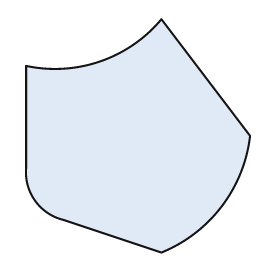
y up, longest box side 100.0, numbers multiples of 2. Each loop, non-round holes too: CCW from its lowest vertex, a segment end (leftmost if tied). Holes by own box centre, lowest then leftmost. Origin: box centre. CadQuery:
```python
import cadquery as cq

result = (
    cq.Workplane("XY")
    .moveTo(10.0, -50.0)
    .threePointArc((36.0, -30.0), (48.0, 0.0))
    .lineTo(10.0, 50.0)
    .threePointArc((-16.0, 32.0), (-48.0, 30.0))
    .lineTo(-48.0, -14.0)
    .threePointArc((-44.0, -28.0), (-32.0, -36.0))
    .close()
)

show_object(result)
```